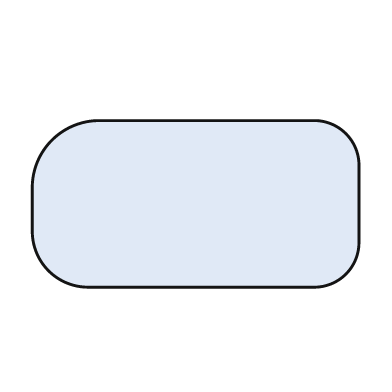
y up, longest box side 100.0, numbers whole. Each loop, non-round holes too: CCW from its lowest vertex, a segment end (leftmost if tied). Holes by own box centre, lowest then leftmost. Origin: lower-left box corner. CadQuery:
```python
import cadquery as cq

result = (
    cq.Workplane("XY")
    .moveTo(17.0, 0.0)
    .lineTo(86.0, 0.0)
    .threePointArc((96.0, 4.0), (100.0, 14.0))
    .lineTo(100.0, 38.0)
    .threePointArc((96.0, 47.0), (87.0, 51.0))
    .lineTo(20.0, 51.0)
    .threePointArc((6.0, 45.0), (0.0, 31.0))
    .lineTo(0.0, 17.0)
    .threePointArc((5.0, 5.0), (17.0, 0.0))
    .close()
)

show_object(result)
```